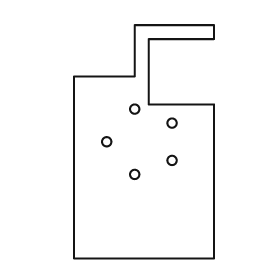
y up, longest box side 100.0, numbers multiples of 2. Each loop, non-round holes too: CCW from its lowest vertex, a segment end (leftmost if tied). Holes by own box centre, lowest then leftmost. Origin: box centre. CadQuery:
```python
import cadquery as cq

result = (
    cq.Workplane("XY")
    .moveTo(-30.0, -50.0)
    .lineTo(30.0, -50.0)
    .lineTo(30.0, 16.0)
    .lineTo(2.0, 16.0)
    .lineTo(2.0, 44.0)
    .lineTo(30.0, 44.0)
    .lineTo(30.0, 50.0)
    .lineTo(-4.0, 50.0)
    .lineTo(-4.0, 28.0)
    .lineTo(-30.0, 28.0)
    .close()
    .moveTo(-4.0, -14.0)
    .circle(2.0)
    .moveTo(12.0, -8.0)
    .circle(2.0)
    .moveTo(-16.0, 0.0)
    .circle(2.0)
    .moveTo(12.0, 8.0)
    .circle(2.0)
    .moveTo(-4.0, 14.0)
    .circle(2.0)
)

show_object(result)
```